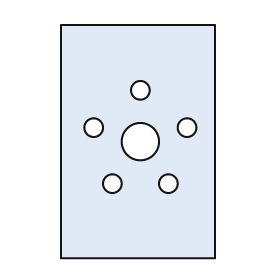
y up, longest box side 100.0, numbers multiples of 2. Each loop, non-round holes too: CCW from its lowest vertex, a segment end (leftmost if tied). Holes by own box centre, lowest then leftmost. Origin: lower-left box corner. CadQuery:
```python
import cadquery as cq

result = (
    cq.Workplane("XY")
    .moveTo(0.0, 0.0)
    .lineTo(66.0, 0.0)
    .lineTo(66.0, 100.0)
    .lineTo(0.0, 100.0)
    .close()
    .moveTo(22.0, 32.0)
    .circle(4.0)
    .moveTo(46.0, 32.0)
    .circle(4.0)
    .moveTo(34.0, 50.0)
    .circle(8.0)
    .moveTo(14.0, 56.0)
    .circle(4.0)
    .moveTo(54.0, 56.0)
    .circle(4.0)
    .moveTo(34.0, 72.0)
    .circle(4.0)
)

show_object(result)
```